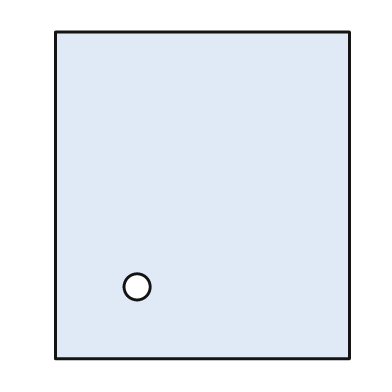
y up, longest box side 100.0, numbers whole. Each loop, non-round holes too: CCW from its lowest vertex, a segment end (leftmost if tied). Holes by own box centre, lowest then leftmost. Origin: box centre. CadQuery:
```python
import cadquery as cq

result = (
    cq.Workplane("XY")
    .moveTo(-45.0, -50.0)
    .lineTo(45.0, -50.0)
    .lineTo(45.0, 50.0)
    .lineTo(-45.0, 50.0)
    .close()
    .moveTo(-20.0, -28.0)
    .circle(4.0)
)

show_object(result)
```